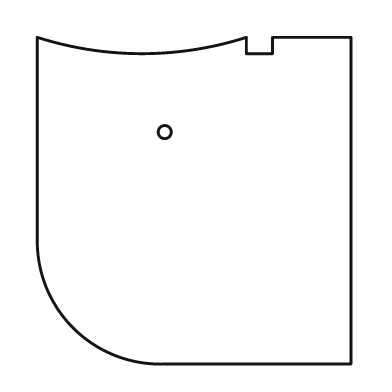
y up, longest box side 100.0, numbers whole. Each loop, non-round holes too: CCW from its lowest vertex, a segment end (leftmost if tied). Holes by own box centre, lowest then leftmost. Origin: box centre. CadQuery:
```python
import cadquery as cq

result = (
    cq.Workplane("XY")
    .moveTo(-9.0, -50.0)
    .lineTo(48.0, -50.0)
    .lineTo(48.0, 50.0)
    .lineTo(24.0, 50.0)
    .lineTo(24.0, 45.0)
    .lineTo(16.0, 45.0)
    .lineTo(16.0, 50.0)
    .threePointArc((-16.0, 45.0), (-48.0, 50.0))
    .lineTo(-48.0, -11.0)
    .threePointArc((-37.0, -39.0), (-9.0, -50.0))
    .close()
    .moveTo(-9.0, 21.0)
    .circle(2.0)
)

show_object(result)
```